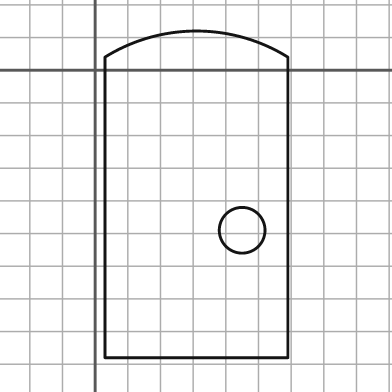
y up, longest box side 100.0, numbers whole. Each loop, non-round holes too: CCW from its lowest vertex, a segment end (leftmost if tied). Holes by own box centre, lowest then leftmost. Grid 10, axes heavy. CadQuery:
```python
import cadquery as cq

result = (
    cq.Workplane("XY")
    .moveTo(3.0, -88.0)
    .lineTo(59.0, -88.0)
    .lineTo(59.0, 4.0)
    .threePointArc((31.0, 12.0), (3.0, 4.0))
    .close()
    .moveTo(45.0, -49.0)
    .circle(7.0)
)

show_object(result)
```